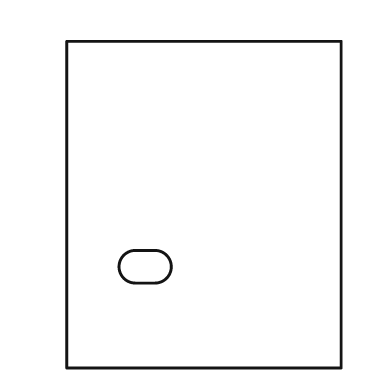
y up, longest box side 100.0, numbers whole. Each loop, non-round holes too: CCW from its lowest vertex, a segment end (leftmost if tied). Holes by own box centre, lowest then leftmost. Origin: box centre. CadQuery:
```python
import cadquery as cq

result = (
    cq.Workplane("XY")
    .moveTo(-42.0, -50.0)
    .lineTo(42.0, -50.0)
    .lineTo(42.0, 50.0)
    .lineTo(-42.0, 50.0)
    .close()
    .moveTo(-21.0, -24.0)
    .lineTo(-15.0, -24.0)
    .threePointArc((-10.0, -19.0), (-15.0, -14.0))
    .lineTo(-21.0, -14.0)
    .threePointArc((-26.0, -19.0), (-21.0, -24.0))
    .close()
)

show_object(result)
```